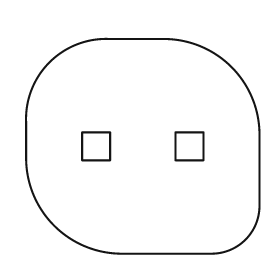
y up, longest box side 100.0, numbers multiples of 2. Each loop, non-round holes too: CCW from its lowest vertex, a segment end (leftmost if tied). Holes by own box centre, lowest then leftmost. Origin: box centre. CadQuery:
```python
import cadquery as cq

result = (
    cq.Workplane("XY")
    .moveTo(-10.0, -46.0)
    .lineTo(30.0, -46.0)
    .threePointArc((44.0, -40.0), (50.0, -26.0))
    .lineTo(50.0, 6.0)
    .threePointArc((38.0, 34.0), (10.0, 46.0))
    .lineTo(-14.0, 46.0)
    .threePointArc((-40.0, 36.0), (-50.0, 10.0))
    .lineTo(-50.0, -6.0)
    .threePointArc((-38.0, -34.0), (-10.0, -46.0))
    .close()
    .moveTo(-26.0, -6.0)
    .lineTo(-14.0, -6.0)
    .lineTo(-14.0, 6.0)
    .lineTo(-26.0, 6.0)
    .close()
    .moveTo(14.0, -6.0)
    .lineTo(26.0, -6.0)
    .lineTo(26.0, 6.0)
    .lineTo(14.0, 6.0)
    .close()
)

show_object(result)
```